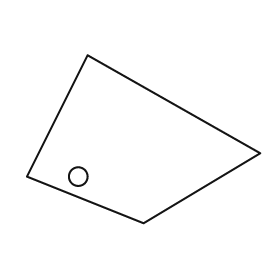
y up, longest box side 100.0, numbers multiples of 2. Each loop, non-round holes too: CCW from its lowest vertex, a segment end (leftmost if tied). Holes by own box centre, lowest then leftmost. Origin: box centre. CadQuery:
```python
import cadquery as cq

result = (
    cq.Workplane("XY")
    .moveTo(0.0, -36.0)
    .lineTo(50.0, -6.0)
    .lineTo(-24.0, 36.0)
    .lineTo(-50.0, -16.0)
    .close()
    .moveTo(-28.0, -16.0)
    .circle(4.0)
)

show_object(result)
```